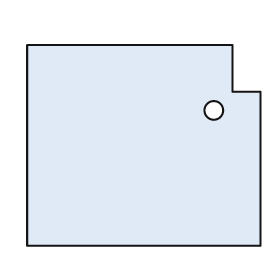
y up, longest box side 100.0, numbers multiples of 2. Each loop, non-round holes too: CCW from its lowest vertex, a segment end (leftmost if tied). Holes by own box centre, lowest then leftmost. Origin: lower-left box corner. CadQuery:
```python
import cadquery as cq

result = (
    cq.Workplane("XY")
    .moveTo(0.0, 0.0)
    .lineTo(100.0, 0.0)
    .lineTo(100.0, 66.0)
    .lineTo(88.0, 66.0)
    .lineTo(88.0, 86.0)
    .lineTo(0.0, 86.0)
    .close()
    .moveTo(80.0, 58.0)
    .circle(4.0)
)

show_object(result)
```